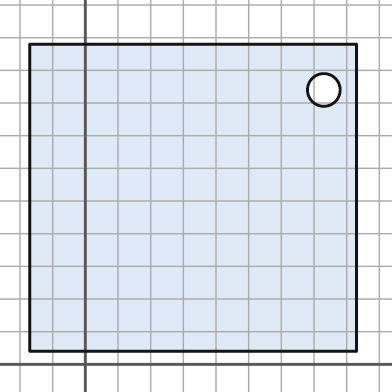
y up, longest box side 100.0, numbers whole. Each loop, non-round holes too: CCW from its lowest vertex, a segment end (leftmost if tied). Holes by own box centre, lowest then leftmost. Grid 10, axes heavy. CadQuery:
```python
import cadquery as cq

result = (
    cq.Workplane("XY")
    .moveTo(-17.0, 4.0)
    .lineTo(83.0, 4.0)
    .lineTo(83.0, 98.0)
    .lineTo(-17.0, 98.0)
    .close()
    .moveTo(73.0, 84.0)
    .circle(5.0)
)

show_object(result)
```